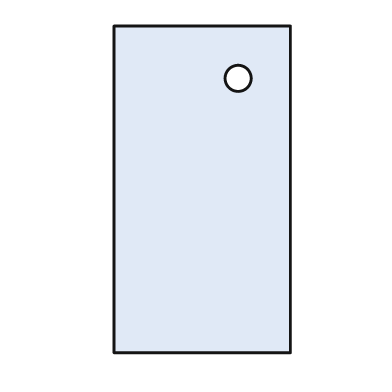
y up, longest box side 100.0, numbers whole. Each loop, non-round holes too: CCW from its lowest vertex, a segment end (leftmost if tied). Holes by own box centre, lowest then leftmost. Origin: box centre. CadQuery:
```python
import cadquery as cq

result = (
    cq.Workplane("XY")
    .moveTo(-27.0, -50.0)
    .lineTo(27.0, -50.0)
    .lineTo(27.0, 50.0)
    .lineTo(-27.0, 50.0)
    .close()
    .moveTo(11.0, 34.0)
    .circle(4.0)
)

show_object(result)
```